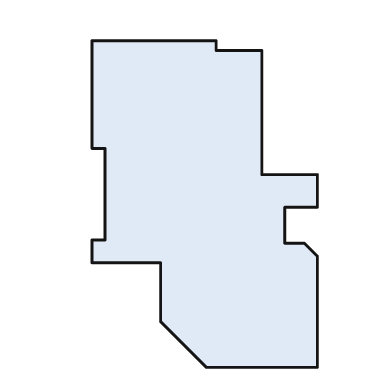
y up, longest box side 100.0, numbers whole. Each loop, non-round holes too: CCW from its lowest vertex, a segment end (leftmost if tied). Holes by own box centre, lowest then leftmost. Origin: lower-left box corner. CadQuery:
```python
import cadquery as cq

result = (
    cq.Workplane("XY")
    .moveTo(35.0, 0.0)
    .lineTo(69.0, 0.0)
    .lineTo(69.0, 34.0)
    .lineTo(65.0, 38.0)
    .lineTo(59.0, 38.0)
    .lineTo(59.0, 49.0)
    .lineTo(69.0, 49.0)
    .lineTo(69.0, 59.0)
    .lineTo(52.0, 59.0)
    .lineTo(52.0, 97.0)
    .lineTo(38.0, 97.0)
    .lineTo(38.0, 100.0)
    .lineTo(0.0, 100.0)
    .lineTo(0.0, 67.0)
    .lineTo(4.0, 67.0)
    .lineTo(4.0, 39.0)
    .lineTo(0.0, 39.0)
    .lineTo(0.0, 32.0)
    .lineTo(21.0, 32.0)
    .lineTo(21.0, 14.0)
    .close()
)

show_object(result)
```